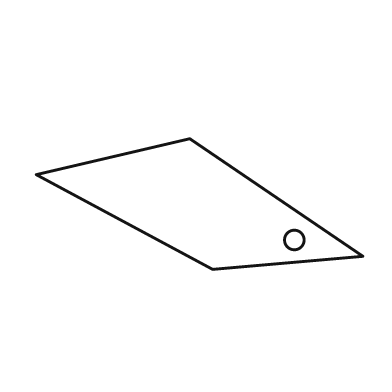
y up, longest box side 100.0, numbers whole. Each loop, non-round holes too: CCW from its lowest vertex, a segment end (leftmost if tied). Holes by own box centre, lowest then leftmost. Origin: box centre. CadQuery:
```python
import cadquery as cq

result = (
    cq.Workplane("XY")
    .moveTo(4.0, -20.0)
    .lineTo(50.0, -16.0)
    .lineTo(-3.0, 20.0)
    .lineTo(-50.0, 9.0)
    .close()
    .moveTo(29.0, -11.0)
    .circle(3.0)
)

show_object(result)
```